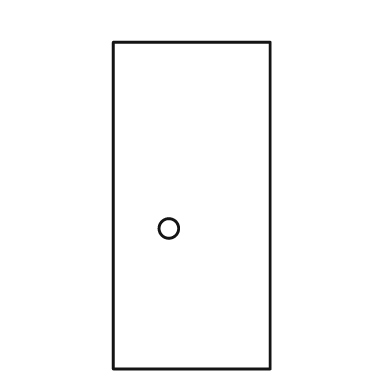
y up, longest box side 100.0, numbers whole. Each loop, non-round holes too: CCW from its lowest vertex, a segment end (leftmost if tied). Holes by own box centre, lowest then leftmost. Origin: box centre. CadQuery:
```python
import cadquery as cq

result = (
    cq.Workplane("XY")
    .moveTo(-24.0, -50.0)
    .lineTo(24.0, -50.0)
    .lineTo(24.0, 50.0)
    .lineTo(-24.0, 50.0)
    .close()
    .moveTo(-7.0, -7.0)
    .circle(3.0)
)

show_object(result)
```